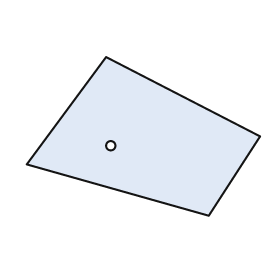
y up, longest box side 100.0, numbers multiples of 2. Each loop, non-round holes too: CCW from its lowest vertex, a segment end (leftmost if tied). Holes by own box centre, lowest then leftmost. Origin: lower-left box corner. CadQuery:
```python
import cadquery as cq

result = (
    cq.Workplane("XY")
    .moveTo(78.0, 0.0)
    .lineTo(100.0, 34.0)
    .lineTo(34.0, 68.0)
    .lineTo(0.0, 22.0)
    .close()
    .moveTo(36.0, 30.0)
    .circle(2.0)
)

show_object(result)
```